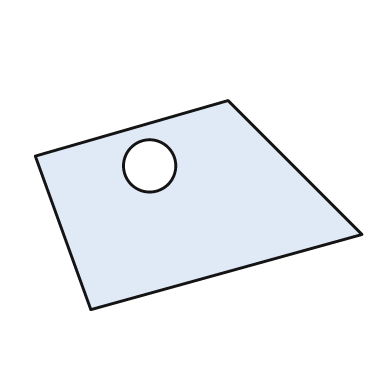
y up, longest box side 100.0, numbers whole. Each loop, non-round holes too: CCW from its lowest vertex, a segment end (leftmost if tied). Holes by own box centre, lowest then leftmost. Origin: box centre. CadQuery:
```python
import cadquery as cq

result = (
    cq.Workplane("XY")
    .moveTo(-33.0, -32.0)
    .lineTo(50.0, -9.0)
    .lineTo(9.0, 32.0)
    .lineTo(-50.0, 15.0)
    .close()
    .moveTo(-15.0, 12.0)
    .circle(8.0)
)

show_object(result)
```